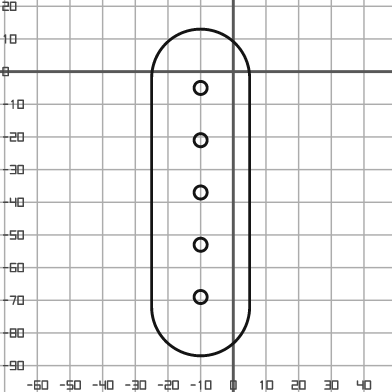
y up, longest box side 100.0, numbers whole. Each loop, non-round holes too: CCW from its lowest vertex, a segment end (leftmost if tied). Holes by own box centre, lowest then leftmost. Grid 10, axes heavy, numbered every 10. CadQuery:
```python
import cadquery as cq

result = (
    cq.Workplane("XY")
    .moveTo(-25.0, -72.0)
    .threePointArc((-10.0, -87.0), (5.0, -72.0))
    .lineTo(5.0, -2.0)
    .threePointArc((-10.0, 13.0), (-25.0, -2.0))
    .close()
    .moveTo(-10.0, -69.0)
    .circle(2.0)
    .moveTo(-10.0, -53.0)
    .circle(2.0)
    .moveTo(-10.0, -37.0)
    .circle(2.0)
    .moveTo(-10.0, -21.0)
    .circle(2.0)
    .moveTo(-10.0, -5.0)
    .circle(2.0)
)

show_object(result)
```